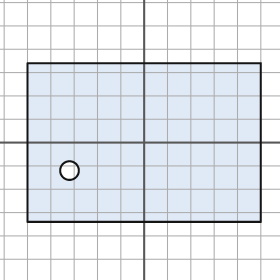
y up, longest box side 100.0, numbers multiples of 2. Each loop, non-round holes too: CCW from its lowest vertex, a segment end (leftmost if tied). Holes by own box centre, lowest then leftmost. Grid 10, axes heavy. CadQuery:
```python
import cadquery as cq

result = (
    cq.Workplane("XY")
    .moveTo(-50.0, -34.0)
    .lineTo(50.0, -34.0)
    .lineTo(50.0, 34.0)
    .lineTo(-50.0, 34.0)
    .close()
    .moveTo(-32.0, -12.0)
    .circle(4.0)
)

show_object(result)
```